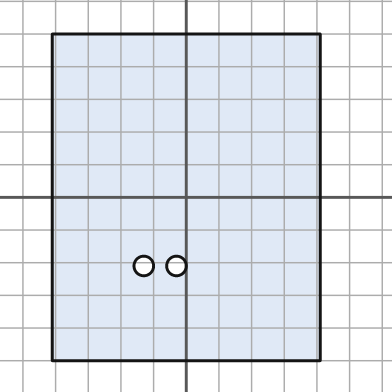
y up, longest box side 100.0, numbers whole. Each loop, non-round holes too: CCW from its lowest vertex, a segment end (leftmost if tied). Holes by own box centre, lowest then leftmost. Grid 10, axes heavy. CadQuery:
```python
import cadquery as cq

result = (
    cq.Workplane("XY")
    .moveTo(-41.0, -50.0)
    .lineTo(41.0, -50.0)
    .lineTo(41.0, 50.0)
    .lineTo(-41.0, 50.0)
    .close()
    .moveTo(-13.0, -21.0)
    .circle(3.0)
    .moveTo(-3.0, -21.0)
    .circle(3.0)
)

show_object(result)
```